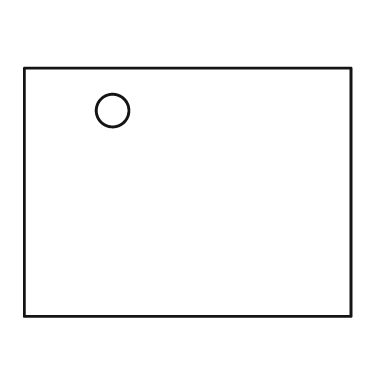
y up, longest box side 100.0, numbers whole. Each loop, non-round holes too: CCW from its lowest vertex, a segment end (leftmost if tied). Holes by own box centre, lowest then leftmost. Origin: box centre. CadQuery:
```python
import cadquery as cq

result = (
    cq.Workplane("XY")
    .moveTo(-50.0, -38.0)
    .lineTo(50.0, -38.0)
    .lineTo(50.0, 38.0)
    .lineTo(-50.0, 38.0)
    .close()
    .moveTo(-23.0, 25.0)
    .circle(5.0)
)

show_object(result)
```